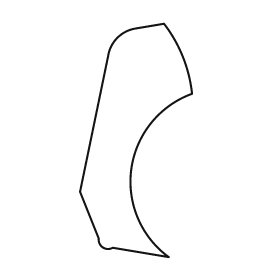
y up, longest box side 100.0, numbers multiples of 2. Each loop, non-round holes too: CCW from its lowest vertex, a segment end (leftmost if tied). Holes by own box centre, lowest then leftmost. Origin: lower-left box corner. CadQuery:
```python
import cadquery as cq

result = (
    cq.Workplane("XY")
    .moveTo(38.0, 0.0)
    .threePointArc((22.0, 38.0), (48.0, 70.0))
    .threePointArc((44.0, 86.0), (36.0, 100.0))
    .lineTo(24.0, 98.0)
    .threePointArc((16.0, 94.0), (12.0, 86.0))
    .lineTo(0.0, 28.0)
    .lineTo(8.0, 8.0)
    .threePointArc((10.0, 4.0), (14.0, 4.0))
    .close()
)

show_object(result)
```